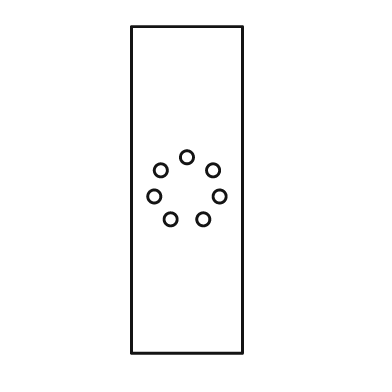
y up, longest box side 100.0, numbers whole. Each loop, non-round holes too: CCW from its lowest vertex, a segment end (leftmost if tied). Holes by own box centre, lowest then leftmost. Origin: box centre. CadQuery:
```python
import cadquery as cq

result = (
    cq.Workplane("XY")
    .moveTo(-17.0, -50.0)
    .lineTo(17.0, -50.0)
    .lineTo(17.0, 50.0)
    .lineTo(-17.0, 50.0)
    .close()
    .moveTo(-5.0, -9.0)
    .circle(2.0)
    .moveTo(5.0, -9.0)
    .circle(2.0)
    .moveTo(-10.0, -2.0)
    .circle(2.0)
    .moveTo(10.0, -2.0)
    .circle(2.0)
    .moveTo(-8.0, 6.0)
    .circle(2.0)
    .moveTo(8.0, 6.0)
    .circle(2.0)
    .moveTo(0.0, 10.0)
    .circle(2.0)
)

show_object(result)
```